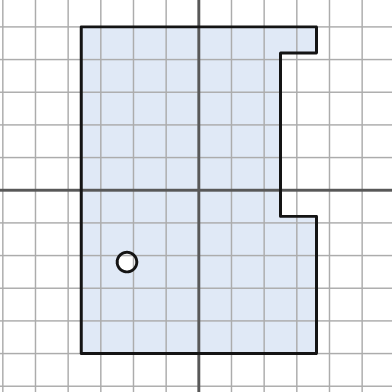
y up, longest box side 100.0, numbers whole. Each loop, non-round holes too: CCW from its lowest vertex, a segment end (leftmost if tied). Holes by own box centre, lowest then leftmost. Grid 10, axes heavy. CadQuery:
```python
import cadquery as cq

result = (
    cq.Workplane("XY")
    .moveTo(-36.0, -50.0)
    .lineTo(36.0, -50.0)
    .lineTo(36.0, -8.0)
    .lineTo(25.0, -8.0)
    .lineTo(25.0, 42.0)
    .lineTo(36.0, 42.0)
    .lineTo(36.0, 50.0)
    .lineTo(-36.0, 50.0)
    .close()
    .moveTo(-22.0, -22.0)
    .circle(3.0)
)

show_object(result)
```